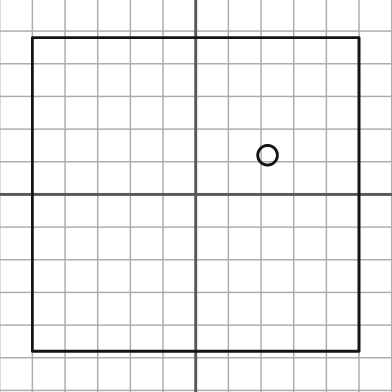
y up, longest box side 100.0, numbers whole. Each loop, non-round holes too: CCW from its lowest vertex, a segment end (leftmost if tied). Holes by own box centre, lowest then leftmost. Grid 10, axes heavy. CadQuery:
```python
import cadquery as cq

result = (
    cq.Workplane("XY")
    .moveTo(-50.0, -48.0)
    .lineTo(50.0, -48.0)
    .lineTo(50.0, 48.0)
    .lineTo(-50.0, 48.0)
    .close()
    .moveTo(22.0, 12.0)
    .circle(3.0)
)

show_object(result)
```